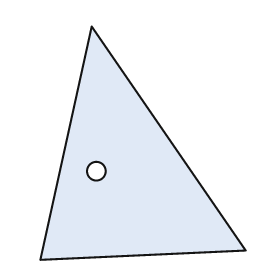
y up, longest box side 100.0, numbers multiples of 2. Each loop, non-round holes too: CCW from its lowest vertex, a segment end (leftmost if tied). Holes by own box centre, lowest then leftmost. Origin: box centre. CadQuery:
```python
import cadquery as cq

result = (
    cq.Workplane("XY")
    .moveTo(-44.0, -50.0)
    .lineTo(44.0, -46.0)
    .lineTo(-22.0, 50.0)
    .close()
    .moveTo(-20.0, -12.0)
    .circle(4.0)
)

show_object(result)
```